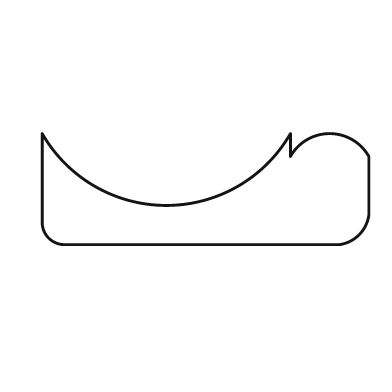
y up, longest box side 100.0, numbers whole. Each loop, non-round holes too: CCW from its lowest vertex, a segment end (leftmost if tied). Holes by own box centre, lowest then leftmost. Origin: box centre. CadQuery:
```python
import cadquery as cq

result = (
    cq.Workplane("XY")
    .moveTo(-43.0, -17.0)
    .lineTo(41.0, -17.0)
    .threePointArc((47.0, -14.0), (50.0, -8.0))
    .lineTo(50.0, 10.0)
    .threePointArc((38.0, 17.0), (26.0, 10.0))
    .lineTo(26.0, 17.0)
    .threePointArc((-12.0, -5.0), (-50.0, 17.0))
    .lineTo(-50.0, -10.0)
    .threePointArc((-48.0, -15.0), (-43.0, -17.0))
    .close()
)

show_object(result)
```